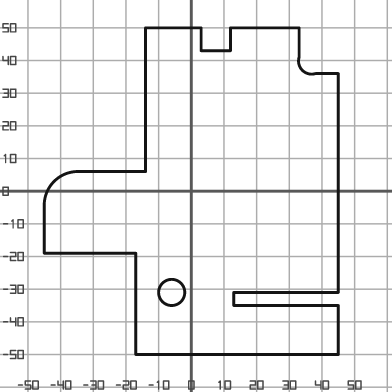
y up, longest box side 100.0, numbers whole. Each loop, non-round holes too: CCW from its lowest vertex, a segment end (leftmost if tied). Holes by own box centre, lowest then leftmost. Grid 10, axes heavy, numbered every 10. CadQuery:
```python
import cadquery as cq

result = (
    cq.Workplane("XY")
    .moveTo(-17.0, -50.0)
    .lineTo(45.0, -50.0)
    .lineTo(45.0, -35.0)
    .lineTo(13.0, -35.0)
    .lineTo(13.0, -31.0)
    .lineTo(45.0, -31.0)
    .lineTo(45.0, 36.0)
    .lineTo(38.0, 36.0)
    .threePointArc((34.0, 37.0), (33.0, 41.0))
    .lineTo(33.0, 50.0)
    .lineTo(12.0, 50.0)
    .lineTo(12.0, 43.0)
    .lineTo(3.0, 43.0)
    .lineTo(3.0, 50.0)
    .lineTo(-14.0, 50.0)
    .lineTo(-14.0, 6.0)
    .lineTo(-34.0, 6.0)
    .threePointArc((-42.0, 3.0), (-45.0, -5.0))
    .lineTo(-45.0, -19.0)
    .lineTo(-17.0, -19.0)
    .close()
    .moveTo(-6.0, -31.0)
    .circle(4.0)
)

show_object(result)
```